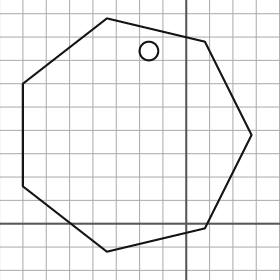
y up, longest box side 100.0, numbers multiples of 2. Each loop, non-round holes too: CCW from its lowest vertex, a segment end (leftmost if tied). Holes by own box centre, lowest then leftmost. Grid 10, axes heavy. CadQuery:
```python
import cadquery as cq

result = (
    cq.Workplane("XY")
    .moveTo(-34.0, -12.0)
    .lineTo(8.0, -2.0)
    .lineTo(28.0, 38.0)
    .lineTo(8.0, 78.0)
    .lineTo(-34.0, 88.0)
    .lineTo(-70.0, 60.0)
    .lineTo(-70.0, 16.0)
    .close()
    .moveTo(-16.0, 74.0)
    .circle(4.0)
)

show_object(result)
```